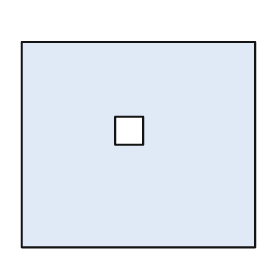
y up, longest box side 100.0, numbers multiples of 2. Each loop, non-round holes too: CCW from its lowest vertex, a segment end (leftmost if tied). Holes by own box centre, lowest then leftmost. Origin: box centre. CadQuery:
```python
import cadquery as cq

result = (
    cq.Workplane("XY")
    .moveTo(-50.0, -44.0)
    .lineTo(50.0, -44.0)
    .lineTo(50.0, 44.0)
    .lineTo(-50.0, 44.0)
    .close()
    .moveTo(-10.0, 0.0)
    .lineTo(2.0, 0.0)
    .lineTo(2.0, 12.0)
    .lineTo(-10.0, 12.0)
    .close()
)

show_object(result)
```